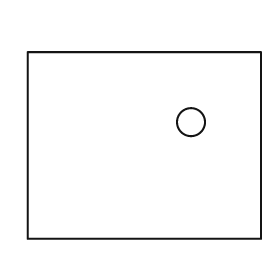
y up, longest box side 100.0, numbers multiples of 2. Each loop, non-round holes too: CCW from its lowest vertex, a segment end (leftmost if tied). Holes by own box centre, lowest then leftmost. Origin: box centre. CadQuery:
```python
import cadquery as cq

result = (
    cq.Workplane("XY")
    .moveTo(-50.0, -40.0)
    .lineTo(50.0, -40.0)
    .lineTo(50.0, 40.0)
    .lineTo(-50.0, 40.0)
    .close()
    .moveTo(20.0, 10.0)
    .circle(6.0)
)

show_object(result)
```